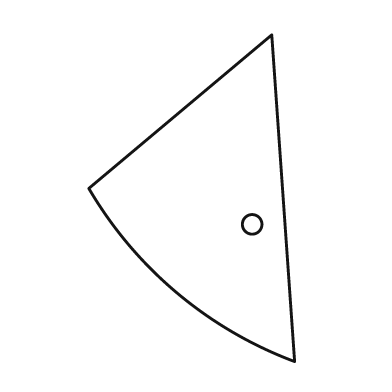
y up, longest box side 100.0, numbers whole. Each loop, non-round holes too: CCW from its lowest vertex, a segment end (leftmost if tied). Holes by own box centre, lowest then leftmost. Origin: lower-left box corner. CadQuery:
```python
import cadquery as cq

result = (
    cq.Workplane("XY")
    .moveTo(63.0, 0.0)
    .lineTo(56.0, 100.0)
    .lineTo(0.0, 53.0)
    .threePointArc((27.0, 21.0), (63.0, 0.0))
    .close()
    .moveTo(50.0, 42.0)
    .circle(3.0)
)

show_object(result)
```